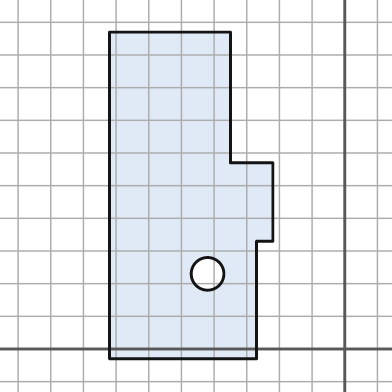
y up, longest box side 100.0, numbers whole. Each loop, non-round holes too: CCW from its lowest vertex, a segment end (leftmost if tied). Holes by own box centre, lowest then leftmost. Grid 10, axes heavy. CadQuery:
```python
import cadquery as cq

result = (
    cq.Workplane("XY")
    .moveTo(-72.0, -3.0)
    .lineTo(-27.0, -3.0)
    .lineTo(-27.0, 33.0)
    .lineTo(-22.0, 33.0)
    .lineTo(-22.0, 57.0)
    .lineTo(-35.0, 57.0)
    .lineTo(-35.0, 97.0)
    .lineTo(-72.0, 97.0)
    .close()
    .moveTo(-42.0, 23.0)
    .circle(5.0)
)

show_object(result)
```